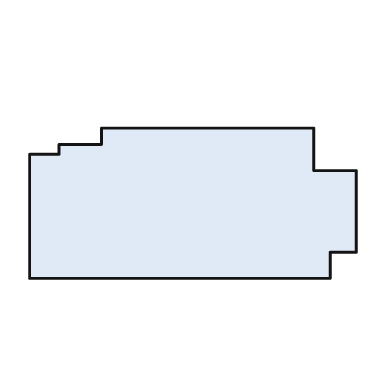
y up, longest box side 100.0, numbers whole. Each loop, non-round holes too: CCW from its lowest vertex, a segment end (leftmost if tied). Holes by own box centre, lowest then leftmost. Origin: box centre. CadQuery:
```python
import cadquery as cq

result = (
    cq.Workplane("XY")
    .moveTo(-50.0, -23.0)
    .lineTo(42.0, -23.0)
    .lineTo(42.0, -15.0)
    .lineTo(50.0, -15.0)
    .lineTo(50.0, 10.0)
    .lineTo(37.0, 10.0)
    .lineTo(37.0, 23.0)
    .lineTo(-28.0, 23.0)
    .lineTo(-28.0, 18.0)
    .lineTo(-41.0, 18.0)
    .lineTo(-41.0, 15.0)
    .lineTo(-50.0, 15.0)
    .close()
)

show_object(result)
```